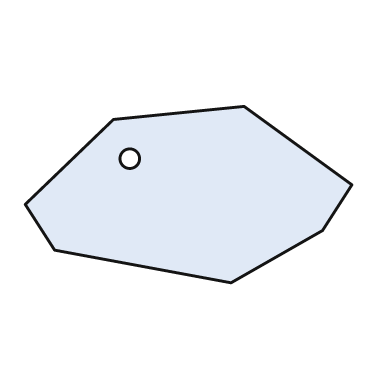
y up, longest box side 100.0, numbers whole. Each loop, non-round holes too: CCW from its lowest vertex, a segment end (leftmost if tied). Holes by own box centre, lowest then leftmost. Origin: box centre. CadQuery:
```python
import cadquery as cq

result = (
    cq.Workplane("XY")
    .moveTo(13.0, -27.0)
    .lineTo(41.0, -11.0)
    .lineTo(50.0, 3.0)
    .lineTo(17.0, 27.0)
    .lineTo(-23.0, 23.0)
    .lineTo(-50.0, -3.0)
    .lineTo(-41.0, -17.0)
    .close()
    .moveTo(-18.0, 11.0)
    .circle(3.0)
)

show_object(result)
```